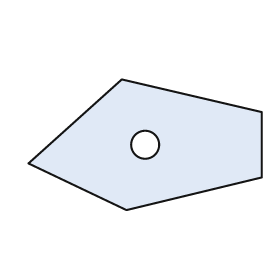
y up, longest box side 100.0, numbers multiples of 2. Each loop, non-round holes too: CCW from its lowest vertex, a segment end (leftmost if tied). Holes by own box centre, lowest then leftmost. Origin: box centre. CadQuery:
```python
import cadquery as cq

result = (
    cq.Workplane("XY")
    .moveTo(-8.0, -28.0)
    .lineTo(50.0, -14.0)
    .lineTo(50.0, 14.0)
    .lineTo(-10.0, 28.0)
    .lineTo(-50.0, -8.0)
    .close()
    .moveTo(0.0, 0.0)
    .circle(6.0)
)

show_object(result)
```